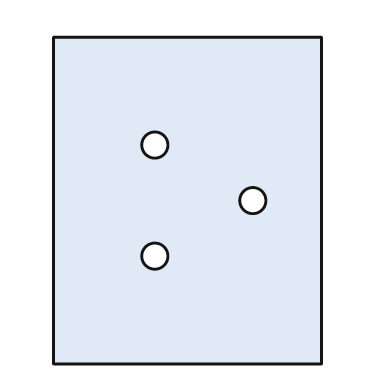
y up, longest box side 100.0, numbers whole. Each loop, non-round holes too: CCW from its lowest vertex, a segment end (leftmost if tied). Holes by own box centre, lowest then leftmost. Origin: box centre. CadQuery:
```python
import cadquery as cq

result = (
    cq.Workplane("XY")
    .moveTo(-41.0, -50.0)
    .lineTo(41.0, -50.0)
    .lineTo(41.0, 50.0)
    .lineTo(-41.0, 50.0)
    .close()
    .moveTo(-10.0, -17.0)
    .circle(4.0)
    .moveTo(20.0, 0.0)
    .circle(4.0)
    .moveTo(-10.0, 17.0)
    .circle(4.0)
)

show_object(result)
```